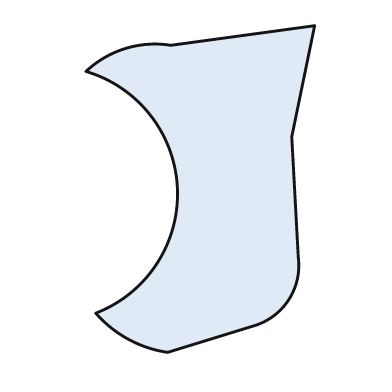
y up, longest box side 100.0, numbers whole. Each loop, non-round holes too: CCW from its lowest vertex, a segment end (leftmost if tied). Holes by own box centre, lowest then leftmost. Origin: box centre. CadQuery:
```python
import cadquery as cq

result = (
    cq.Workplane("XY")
    .moveTo(-10.0, -50.0)
    .lineTo(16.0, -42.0)
    .threePointArc((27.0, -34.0), (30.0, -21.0))
    .lineTo(28.0, 16.0)
    .lineTo(35.0, 50.0)
    .lineTo(-9.0, 44.0)
    .threePointArc((-23.0, 43.0), (-35.0, 36.0))
    .threePointArc((-7.0, 0.0), (-32.0, -38.0))
    .threePointArc((-22.0, -46.0), (-10.0, -50.0))
    .close()
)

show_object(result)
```